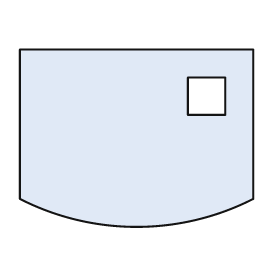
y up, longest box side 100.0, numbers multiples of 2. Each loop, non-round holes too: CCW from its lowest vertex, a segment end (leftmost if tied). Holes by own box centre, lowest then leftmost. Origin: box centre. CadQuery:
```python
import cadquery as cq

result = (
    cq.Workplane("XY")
    .moveTo(-50.0, -26.0)
    .threePointArc((0.0, -38.0), (50.0, -26.0))
    .lineTo(50.0, 38.0)
    .lineTo(-50.0, 38.0)
    .close()
    .moveTo(22.0, 10.0)
    .lineTo(38.0, 10.0)
    .lineTo(38.0, 26.0)
    .lineTo(22.0, 26.0)
    .close()
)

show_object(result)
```